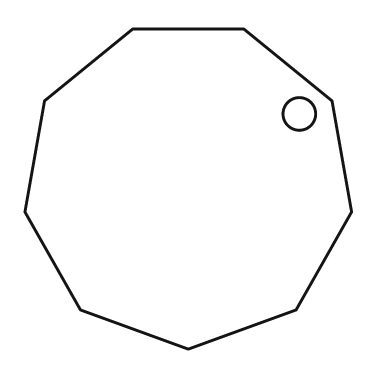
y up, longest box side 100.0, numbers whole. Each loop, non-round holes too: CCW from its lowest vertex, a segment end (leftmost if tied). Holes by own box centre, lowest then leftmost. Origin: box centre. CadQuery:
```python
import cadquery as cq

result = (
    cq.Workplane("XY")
    .moveTo(0.0, -49.0)
    .lineTo(33.0, -37.0)
    .lineTo(50.0, -7.0)
    .lineTo(44.0, 27.0)
    .lineTo(17.0, 49.0)
    .lineTo(-17.0, 49.0)
    .lineTo(-44.0, 27.0)
    .lineTo(-50.0, -7.0)
    .lineTo(-33.0, -37.0)
    .close()
    .moveTo(34.0, 23.0)
    .circle(5.0)
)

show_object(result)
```